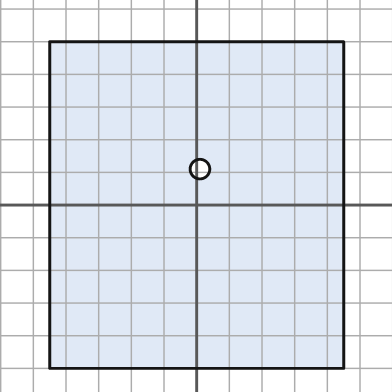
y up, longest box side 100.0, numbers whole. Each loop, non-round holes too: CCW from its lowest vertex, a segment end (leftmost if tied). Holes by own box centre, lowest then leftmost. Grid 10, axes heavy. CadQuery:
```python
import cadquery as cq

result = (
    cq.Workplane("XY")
    .moveTo(-45.0, -50.0)
    .lineTo(45.0, -50.0)
    .lineTo(45.0, 50.0)
    .lineTo(-45.0, 50.0)
    .close()
    .moveTo(1.0, 11.0)
    .circle(3.0)
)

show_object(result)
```